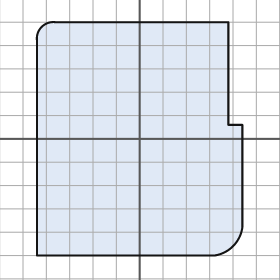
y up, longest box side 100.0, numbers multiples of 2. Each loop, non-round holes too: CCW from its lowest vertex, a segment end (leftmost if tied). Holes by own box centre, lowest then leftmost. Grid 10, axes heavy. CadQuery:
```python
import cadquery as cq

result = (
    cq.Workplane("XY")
    .moveTo(-44.0, -50.0)
    .lineTo(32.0, -50.0)
    .threePointArc((40.0, -46.0), (44.0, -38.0))
    .lineTo(44.0, 6.0)
    .lineTo(38.0, 6.0)
    .lineTo(38.0, 50.0)
    .lineTo(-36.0, 50.0)
    .threePointArc((-42.0, 48.0), (-44.0, 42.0))
    .close()
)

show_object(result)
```